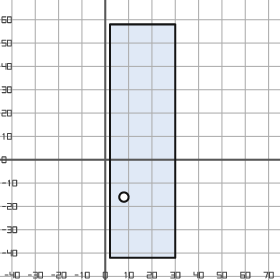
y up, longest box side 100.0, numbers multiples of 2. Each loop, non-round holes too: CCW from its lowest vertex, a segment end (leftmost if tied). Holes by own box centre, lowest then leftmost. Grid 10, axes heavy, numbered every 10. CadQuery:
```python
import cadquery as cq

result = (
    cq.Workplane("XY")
    .moveTo(2.0, -42.0)
    .lineTo(30.0, -42.0)
    .lineTo(30.0, 58.0)
    .lineTo(2.0, 58.0)
    .close()
    .moveTo(8.0, -16.0)
    .circle(2.0)
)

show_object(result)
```